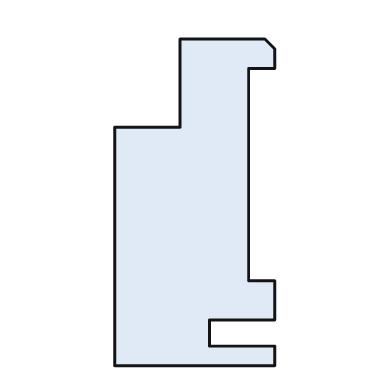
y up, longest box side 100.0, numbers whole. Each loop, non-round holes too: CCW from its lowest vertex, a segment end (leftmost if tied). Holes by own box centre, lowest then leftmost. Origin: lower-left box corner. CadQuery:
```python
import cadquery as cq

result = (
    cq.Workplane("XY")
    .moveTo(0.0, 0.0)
    .lineTo(49.0, 0.0)
    .lineTo(49.0, 6.0)
    .lineTo(29.0, 6.0)
    .lineTo(29.0, 14.0)
    .lineTo(49.0, 14.0)
    .lineTo(49.0, 26.0)
    .lineTo(41.0, 26.0)
    .lineTo(41.0, 91.0)
    .lineTo(49.0, 91.0)
    .lineTo(49.0, 97.0)
    .lineTo(46.0, 100.0)
    .lineTo(20.0, 100.0)
    .lineTo(20.0, 73.0)
    .lineTo(0.0, 73.0)
    .close()
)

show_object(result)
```